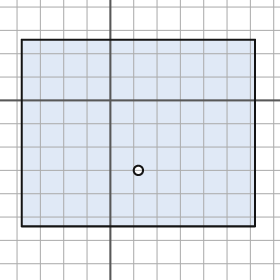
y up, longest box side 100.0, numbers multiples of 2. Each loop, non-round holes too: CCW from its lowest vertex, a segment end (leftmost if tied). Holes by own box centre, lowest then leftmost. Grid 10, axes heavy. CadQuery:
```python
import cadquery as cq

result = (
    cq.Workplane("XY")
    .moveTo(-38.0, -54.0)
    .lineTo(62.0, -54.0)
    .lineTo(62.0, 26.0)
    .lineTo(-38.0, 26.0)
    .close()
    .moveTo(12.0, -30.0)
    .circle(2.0)
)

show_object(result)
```